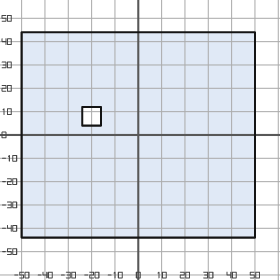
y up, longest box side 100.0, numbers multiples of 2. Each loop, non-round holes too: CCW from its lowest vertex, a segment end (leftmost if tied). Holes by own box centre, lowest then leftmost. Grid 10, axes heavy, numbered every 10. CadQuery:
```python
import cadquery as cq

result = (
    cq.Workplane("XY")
    .moveTo(-50.0, -44.0)
    .lineTo(50.0, -44.0)
    .lineTo(50.0, 44.0)
    .lineTo(-50.0, 44.0)
    .close()
    .moveTo(-24.0, 4.0)
    .lineTo(-16.0, 4.0)
    .lineTo(-16.0, 12.0)
    .lineTo(-24.0, 12.0)
    .close()
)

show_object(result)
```